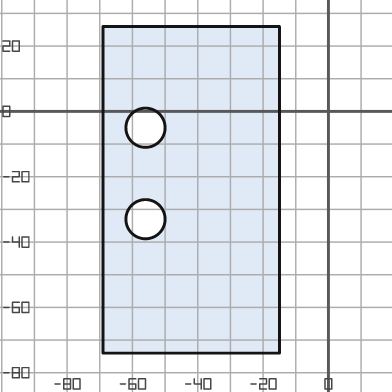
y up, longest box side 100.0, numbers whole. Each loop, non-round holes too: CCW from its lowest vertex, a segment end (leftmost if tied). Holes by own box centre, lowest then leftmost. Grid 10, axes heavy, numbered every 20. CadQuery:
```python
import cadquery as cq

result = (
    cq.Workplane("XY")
    .moveTo(-69.0, -74.0)
    .lineTo(-15.0, -74.0)
    .lineTo(-15.0, 26.0)
    .lineTo(-69.0, 26.0)
    .close()
    .moveTo(-56.0, -33.0)
    .circle(6.0)
    .moveTo(-56.0, -5.0)
    .circle(6.0)
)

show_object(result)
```